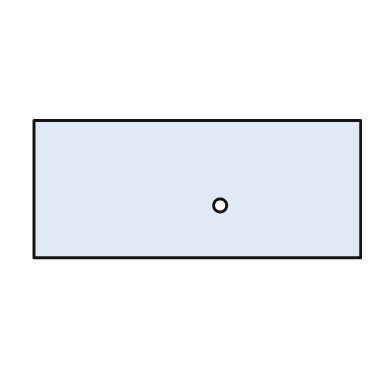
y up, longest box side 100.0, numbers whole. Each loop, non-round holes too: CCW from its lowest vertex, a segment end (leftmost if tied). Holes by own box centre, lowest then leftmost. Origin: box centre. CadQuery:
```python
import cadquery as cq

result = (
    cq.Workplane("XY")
    .moveTo(-50.0, -21.0)
    .lineTo(50.0, -21.0)
    .lineTo(50.0, 21.0)
    .lineTo(-50.0, 21.0)
    .close()
    .moveTo(7.0, -5.0)
    .circle(2.0)
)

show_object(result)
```